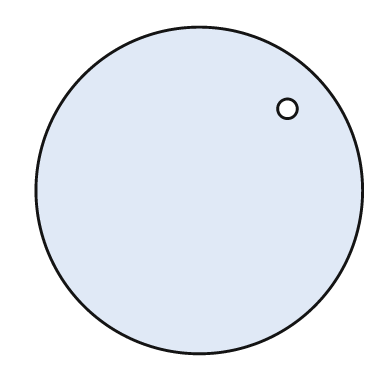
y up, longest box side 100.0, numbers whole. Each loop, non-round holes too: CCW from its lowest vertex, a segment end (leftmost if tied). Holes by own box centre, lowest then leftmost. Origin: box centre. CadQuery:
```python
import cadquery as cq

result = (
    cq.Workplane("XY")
    .moveTo(0.0, 0.0)
    .circle(50.0)
    .moveTo(27.0, 25.0)
    .circle(3.0)
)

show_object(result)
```